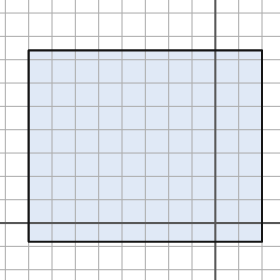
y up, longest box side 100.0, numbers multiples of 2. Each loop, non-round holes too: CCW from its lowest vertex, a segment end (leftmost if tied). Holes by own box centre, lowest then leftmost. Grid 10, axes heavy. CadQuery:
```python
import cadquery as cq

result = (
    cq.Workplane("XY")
    .moveTo(-80.0, -8.0)
    .lineTo(20.0, -8.0)
    .lineTo(20.0, 74.0)
    .lineTo(-80.0, 74.0)
    .close()
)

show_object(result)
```